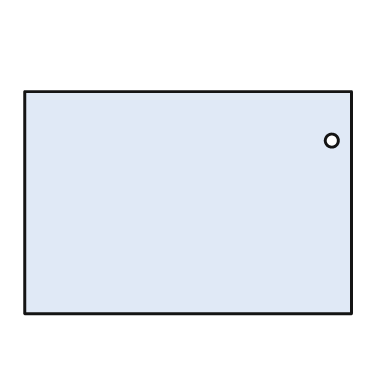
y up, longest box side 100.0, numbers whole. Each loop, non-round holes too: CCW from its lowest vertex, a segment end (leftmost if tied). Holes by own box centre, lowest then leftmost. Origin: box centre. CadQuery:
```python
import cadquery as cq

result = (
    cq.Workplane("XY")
    .moveTo(-50.0, -34.0)
    .lineTo(50.0, -34.0)
    .lineTo(50.0, 34.0)
    .lineTo(-50.0, 34.0)
    .close()
    .moveTo(44.0, 19.0)
    .circle(2.0)
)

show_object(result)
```